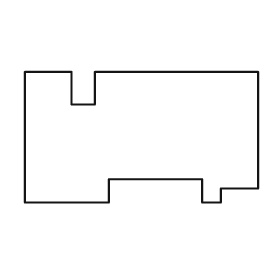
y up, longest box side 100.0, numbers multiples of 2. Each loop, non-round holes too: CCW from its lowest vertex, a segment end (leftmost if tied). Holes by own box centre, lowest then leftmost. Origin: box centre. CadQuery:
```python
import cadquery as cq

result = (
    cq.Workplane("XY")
    .moveTo(-50.0, -28.0)
    .lineTo(-14.0, -28.0)
    .lineTo(-14.0, -18.0)
    .lineTo(26.0, -18.0)
    .lineTo(26.0, -28.0)
    .lineTo(34.0, -28.0)
    .lineTo(34.0, -22.0)
    .lineTo(50.0, -22.0)
    .lineTo(50.0, 28.0)
    .lineTo(-20.0, 28.0)
    .lineTo(-20.0, 14.0)
    .lineTo(-30.0, 14.0)
    .lineTo(-30.0, 28.0)
    .lineTo(-50.0, 28.0)
    .close()
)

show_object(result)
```